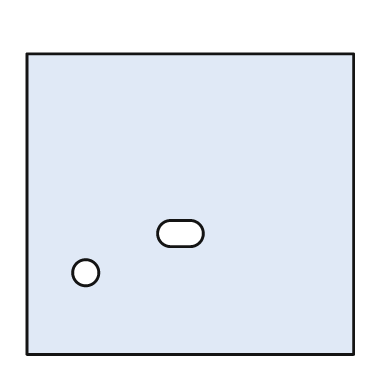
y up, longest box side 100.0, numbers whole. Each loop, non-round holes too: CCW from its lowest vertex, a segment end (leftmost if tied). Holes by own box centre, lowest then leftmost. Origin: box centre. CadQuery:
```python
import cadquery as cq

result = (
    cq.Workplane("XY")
    .moveTo(-50.0, -46.0)
    .lineTo(50.0, -46.0)
    .lineTo(50.0, 46.0)
    .lineTo(-50.0, 46.0)
    .close()
    .moveTo(-32.0, -21.0)
    .circle(4.0)
    .moveTo(-6.0, -13.0)
    .lineTo(0.0, -13.0)
    .threePointArc((4.0, -9.0), (0.0, -5.0))
    .lineTo(-6.0, -5.0)
    .threePointArc((-10.0, -9.0), (-6.0, -13.0))
    .close()
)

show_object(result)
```